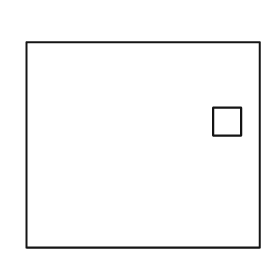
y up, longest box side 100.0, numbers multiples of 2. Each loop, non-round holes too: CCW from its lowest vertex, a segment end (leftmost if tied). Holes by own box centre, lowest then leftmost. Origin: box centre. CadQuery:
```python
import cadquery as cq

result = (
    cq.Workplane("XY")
    .moveTo(-50.0, -44.0)
    .lineTo(50.0, -44.0)
    .lineTo(50.0, 44.0)
    .lineTo(-50.0, 44.0)
    .close()
    .moveTo(30.0, 4.0)
    .lineTo(42.0, 4.0)
    .lineTo(42.0, 16.0)
    .lineTo(30.0, 16.0)
    .close()
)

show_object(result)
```